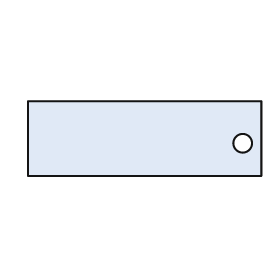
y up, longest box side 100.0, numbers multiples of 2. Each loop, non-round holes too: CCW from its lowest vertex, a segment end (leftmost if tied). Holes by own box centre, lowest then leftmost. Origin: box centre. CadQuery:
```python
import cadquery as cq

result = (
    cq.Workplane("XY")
    .moveTo(-50.0, -16.0)
    .lineTo(50.0, -16.0)
    .lineTo(50.0, 16.0)
    .lineTo(-50.0, 16.0)
    .close()
    .moveTo(42.0, -2.0)
    .circle(4.0)
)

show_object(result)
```